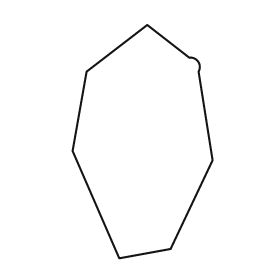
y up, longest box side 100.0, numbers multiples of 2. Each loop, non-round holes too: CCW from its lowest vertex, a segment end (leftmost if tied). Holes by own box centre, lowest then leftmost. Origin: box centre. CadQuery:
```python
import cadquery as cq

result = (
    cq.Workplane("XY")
    .moveTo(-10.0, -50.0)
    .lineTo(12.0, -46.0)
    .lineTo(30.0, -8.0)
    .lineTo(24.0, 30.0)
    .threePointArc((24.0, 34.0), (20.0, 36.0))
    .lineTo(2.0, 50.0)
    .lineTo(-24.0, 30.0)
    .lineTo(-30.0, -4.0)
    .close()
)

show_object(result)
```